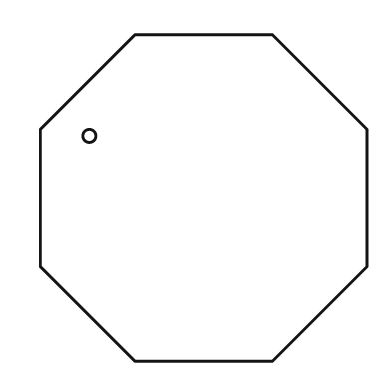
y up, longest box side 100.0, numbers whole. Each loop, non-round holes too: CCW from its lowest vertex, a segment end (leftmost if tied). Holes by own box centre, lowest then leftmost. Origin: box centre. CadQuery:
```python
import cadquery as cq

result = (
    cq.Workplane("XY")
    .moveTo(-21.0, -50.0)
    .lineTo(21.0, -50.0)
    .lineTo(50.0, -21.0)
    .lineTo(50.0, 21.0)
    .lineTo(21.0, 50.0)
    .lineTo(-21.0, 50.0)
    .lineTo(-50.0, 21.0)
    .lineTo(-50.0, -21.0)
    .close()
    .moveTo(-35.0, 19.0)
    .circle(2.0)
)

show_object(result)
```